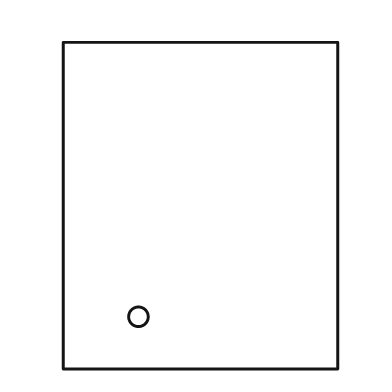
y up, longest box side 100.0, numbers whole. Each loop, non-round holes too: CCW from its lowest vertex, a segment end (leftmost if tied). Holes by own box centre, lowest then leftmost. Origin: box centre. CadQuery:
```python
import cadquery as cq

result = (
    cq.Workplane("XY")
    .moveTo(-42.0, -50.0)
    .lineTo(42.0, -50.0)
    .lineTo(42.0, 50.0)
    .lineTo(-42.0, 50.0)
    .close()
    .moveTo(-19.0, -34.0)
    .circle(3.0)
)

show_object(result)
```